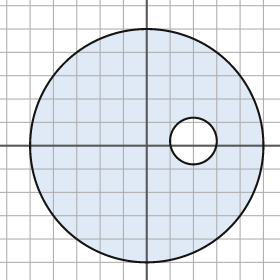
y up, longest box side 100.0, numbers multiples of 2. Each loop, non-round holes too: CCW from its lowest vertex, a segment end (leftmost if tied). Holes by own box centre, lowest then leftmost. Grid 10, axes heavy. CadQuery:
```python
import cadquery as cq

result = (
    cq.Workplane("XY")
    .moveTo(0.0, 0.0)
    .circle(50.0)
    .moveTo(20.0, 2.0)
    .circle(10.0)
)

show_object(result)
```